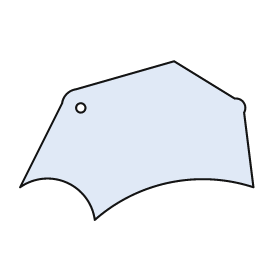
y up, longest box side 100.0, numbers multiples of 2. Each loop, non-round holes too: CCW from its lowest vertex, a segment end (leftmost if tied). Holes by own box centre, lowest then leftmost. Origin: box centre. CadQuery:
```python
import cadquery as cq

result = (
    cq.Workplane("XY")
    .moveTo(-18.0, -34.0)
    .threePointArc((14.0, -18.0), (50.0, -20.0))
    .lineTo(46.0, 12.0)
    .threePointArc((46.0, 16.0), (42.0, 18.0))
    .lineTo(16.0, 34.0)
    .lineTo(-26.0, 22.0)
    .threePointArc((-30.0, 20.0), (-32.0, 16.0))
    .lineTo(-50.0, -20.0)
    .threePointArc((-30.0, -18.0), (-18.0, -34.0))
    .close()
    .moveTo(-24.0, 14.0)
    .circle(2.0)
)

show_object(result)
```